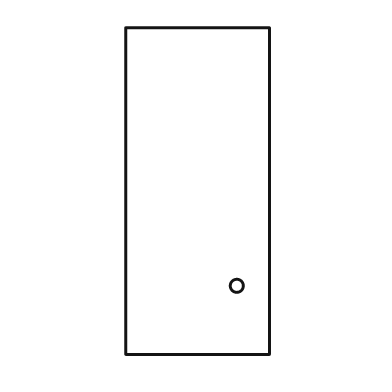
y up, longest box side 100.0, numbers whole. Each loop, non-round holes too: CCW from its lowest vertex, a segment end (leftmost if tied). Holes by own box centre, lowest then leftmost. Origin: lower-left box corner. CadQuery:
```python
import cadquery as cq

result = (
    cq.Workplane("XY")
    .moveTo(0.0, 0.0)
    .lineTo(44.0, 0.0)
    .lineTo(44.0, 100.0)
    .lineTo(0.0, 100.0)
    .close()
    .moveTo(34.0, 21.0)
    .circle(2.0)
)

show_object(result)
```